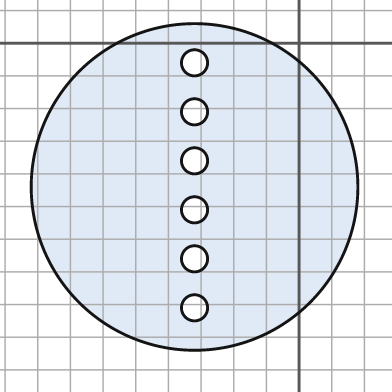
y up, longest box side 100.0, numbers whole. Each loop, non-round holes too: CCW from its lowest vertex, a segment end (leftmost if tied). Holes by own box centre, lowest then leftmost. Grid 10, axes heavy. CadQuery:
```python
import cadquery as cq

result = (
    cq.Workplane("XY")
    .moveTo(-32.0, -44.0)
    .circle(50.0)
    .moveTo(-32.0, -81.0)
    .circle(4.0)
    .moveTo(-32.0, -66.0)
    .circle(4.0)
    .moveTo(-32.0, -51.0)
    .circle(4.0)
    .moveTo(-32.0, -36.0)
    .circle(4.0)
    .moveTo(-32.0, -21.0)
    .circle(4.0)
    .moveTo(-32.0, -6.0)
    .circle(4.0)
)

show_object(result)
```